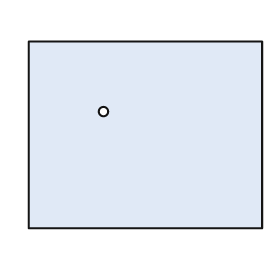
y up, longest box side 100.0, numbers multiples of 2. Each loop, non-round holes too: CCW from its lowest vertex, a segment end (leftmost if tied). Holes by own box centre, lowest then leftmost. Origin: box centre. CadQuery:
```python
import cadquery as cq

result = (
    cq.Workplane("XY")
    .moveTo(-50.0, -40.0)
    .lineTo(50.0, -40.0)
    .lineTo(50.0, 40.0)
    .lineTo(-50.0, 40.0)
    .close()
    .moveTo(-18.0, 10.0)
    .circle(2.0)
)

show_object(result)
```